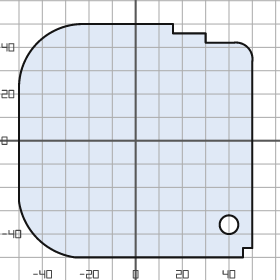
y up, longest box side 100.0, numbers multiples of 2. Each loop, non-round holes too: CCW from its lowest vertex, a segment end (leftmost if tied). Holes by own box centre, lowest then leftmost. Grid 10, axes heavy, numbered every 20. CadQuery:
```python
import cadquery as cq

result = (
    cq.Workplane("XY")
    .moveTo(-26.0, -50.0)
    .lineTo(46.0, -50.0)
    .lineTo(46.0, -46.0)
    .lineTo(50.0, -46.0)
    .lineTo(50.0, 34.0)
    .threePointArc((48.0, 40.0), (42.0, 42.0))
    .lineTo(30.0, 42.0)
    .lineTo(30.0, 46.0)
    .lineTo(16.0, 46.0)
    .lineTo(16.0, 50.0)
    .lineTo(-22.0, 50.0)
    .threePointArc((-42.0, 42.0), (-50.0, 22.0))
    .lineTo(-50.0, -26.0)
    .threePointArc((-42.0, -42.0), (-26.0, -50.0))
    .close()
    .moveTo(40.0, -36.0)
    .circle(4.0)
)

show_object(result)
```